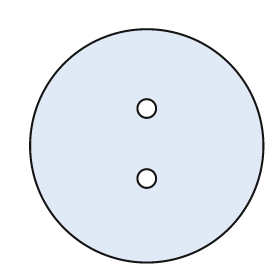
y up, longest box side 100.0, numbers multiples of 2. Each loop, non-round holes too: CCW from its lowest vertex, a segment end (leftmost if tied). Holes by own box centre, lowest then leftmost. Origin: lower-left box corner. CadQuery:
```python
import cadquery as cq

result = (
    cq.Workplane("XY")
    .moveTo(50.0, 50.0)
    .circle(50.0)
    .moveTo(50.0, 36.0)
    .circle(4.0)
    .moveTo(50.0, 66.0)
    .circle(4.0)
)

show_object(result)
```